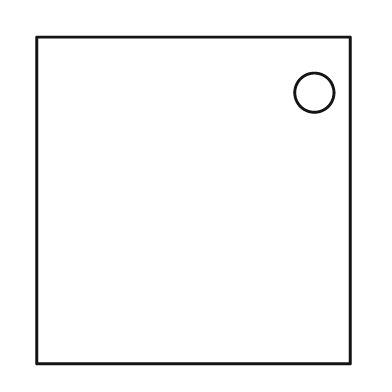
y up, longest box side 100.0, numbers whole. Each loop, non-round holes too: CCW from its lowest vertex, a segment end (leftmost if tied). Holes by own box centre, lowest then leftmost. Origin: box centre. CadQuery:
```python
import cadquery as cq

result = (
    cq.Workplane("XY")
    .moveTo(-48.0, -50.0)
    .lineTo(48.0, -50.0)
    .lineTo(48.0, 50.0)
    .lineTo(-48.0, 50.0)
    .close()
    .moveTo(37.0, 33.0)
    .circle(6.0)
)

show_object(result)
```